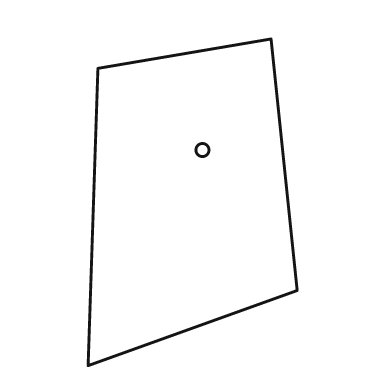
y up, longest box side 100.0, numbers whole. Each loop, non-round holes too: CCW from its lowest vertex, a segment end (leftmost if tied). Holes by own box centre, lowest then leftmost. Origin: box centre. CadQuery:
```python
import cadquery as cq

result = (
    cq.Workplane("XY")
    .moveTo(-32.0, -50.0)
    .lineTo(32.0, -27.0)
    .lineTo(24.0, 50.0)
    .lineTo(-29.0, 41.0)
    .close()
    .moveTo(3.0, 16.0)
    .circle(2.0)
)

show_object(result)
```